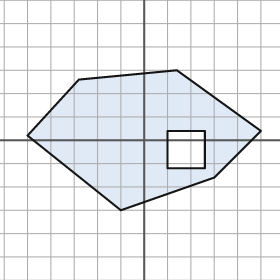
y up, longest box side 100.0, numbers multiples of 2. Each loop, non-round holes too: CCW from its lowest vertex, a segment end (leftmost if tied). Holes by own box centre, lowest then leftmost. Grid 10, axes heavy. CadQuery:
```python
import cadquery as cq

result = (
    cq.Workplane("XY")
    .moveTo(-10.0, -30.0)
    .lineTo(30.0, -16.0)
    .lineTo(50.0, 4.0)
    .lineTo(14.0, 30.0)
    .lineTo(-28.0, 26.0)
    .lineTo(-50.0, 2.0)
    .close()
    .moveTo(10.0, -12.0)
    .lineTo(26.0, -12.0)
    .lineTo(26.0, 4.0)
    .lineTo(10.0, 4.0)
    .close()
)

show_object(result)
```